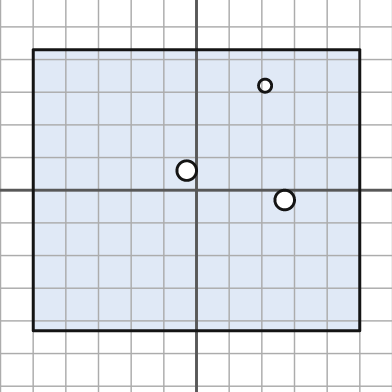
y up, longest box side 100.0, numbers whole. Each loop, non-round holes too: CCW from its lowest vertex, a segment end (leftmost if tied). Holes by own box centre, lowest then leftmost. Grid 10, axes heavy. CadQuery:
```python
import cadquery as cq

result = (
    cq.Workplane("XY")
    .moveTo(-50.0, -43.0)
    .lineTo(50.0, -43.0)
    .lineTo(50.0, 43.0)
    .lineTo(-50.0, 43.0)
    .close()
    .moveTo(27.0, -3.0)
    .circle(3.0)
    .moveTo(-3.0, 6.0)
    .circle(3.0)
    .moveTo(21.0, 32.0)
    .circle(2.0)
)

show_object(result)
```